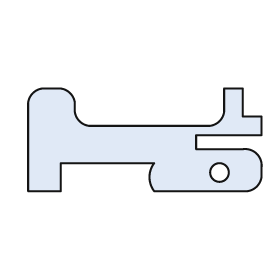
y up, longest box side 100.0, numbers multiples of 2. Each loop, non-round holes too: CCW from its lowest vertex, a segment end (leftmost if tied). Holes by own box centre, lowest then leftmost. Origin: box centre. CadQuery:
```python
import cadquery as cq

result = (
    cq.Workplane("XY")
    .moveTo(-50.0, -22.0)
    .lineTo(-36.0, -22.0)
    .lineTo(-36.0, -10.0)
    .lineTo(4.0, -10.0)
    .threePointArc((2.0, -16.0), (4.0, -22.0))
    .lineTo(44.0, -22.0)
    .threePointArc((48.0, -20.0), (50.0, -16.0))
    .lineTo(50.0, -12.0)
    .threePointArc((48.0, -6.0), (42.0, -4.0))
    .lineTo(22.0, -4.0)
    .lineTo(22.0, 2.0)
    .lineTo(50.0, 2.0)
    .lineTo(50.0, 10.0)
    .lineTo(42.0, 10.0)
    .lineTo(42.0, 22.0)
    .lineTo(34.0, 22.0)
    .lineTo(34.0, 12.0)
    .threePointArc((32.0, 8.0), (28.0, 6.0))
    .lineTo(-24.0, 6.0)
    .threePointArc((-28.0, 8.0), (-30.0, 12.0))
    .lineTo(-30.0, 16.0)
    .threePointArc((-32.0, 20.0), (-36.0, 22.0))
    .lineTo(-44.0, 22.0)
    .threePointArc((-48.0, 20.0), (-50.0, 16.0))
    .close()
    .moveTo(32.0, -14.0)
    .circle(4.0)
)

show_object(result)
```